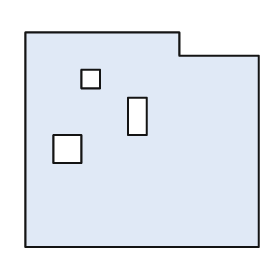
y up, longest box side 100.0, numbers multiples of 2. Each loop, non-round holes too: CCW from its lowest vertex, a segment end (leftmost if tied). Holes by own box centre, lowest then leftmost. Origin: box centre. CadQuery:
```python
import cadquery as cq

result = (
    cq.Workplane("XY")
    .moveTo(-50.0, -46.0)
    .lineTo(50.0, -46.0)
    .lineTo(50.0, 36.0)
    .lineTo(16.0, 36.0)
    .lineTo(16.0, 46.0)
    .lineTo(-50.0, 46.0)
    .close()
    .moveTo(-38.0, -10.0)
    .lineTo(-26.0, -10.0)
    .lineTo(-26.0, 2.0)
    .lineTo(-38.0, 2.0)
    .close()
    .moveTo(-6.0, 2.0)
    .lineTo(2.0, 2.0)
    .lineTo(2.0, 18.0)
    .lineTo(-6.0, 18.0)
    .close()
    .moveTo(-26.0, 22.0)
    .lineTo(-18.0, 22.0)
    .lineTo(-18.0, 30.0)
    .lineTo(-26.0, 30.0)
    .close()
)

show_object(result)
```